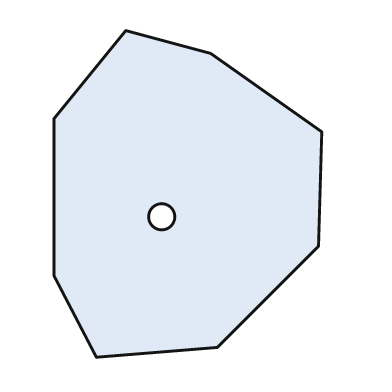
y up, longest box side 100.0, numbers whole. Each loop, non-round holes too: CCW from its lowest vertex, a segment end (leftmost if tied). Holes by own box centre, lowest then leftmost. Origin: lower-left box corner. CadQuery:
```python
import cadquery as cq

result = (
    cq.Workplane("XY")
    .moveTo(13.0, 0.0)
    .lineTo(50.0, 3.0)
    .lineTo(81.0, 34.0)
    .lineTo(82.0, 69.0)
    .lineTo(48.0, 93.0)
    .lineTo(22.0, 100.0)
    .lineTo(0.0, 73.0)
    .lineTo(0.0, 25.0)
    .close()
    .moveTo(33.0, 43.0)
    .circle(4.0)
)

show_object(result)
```